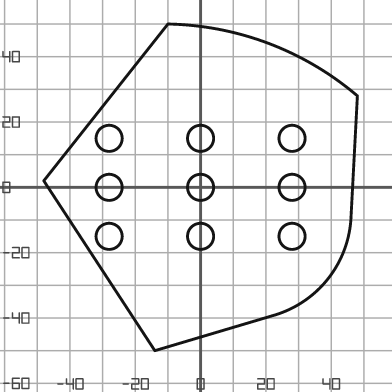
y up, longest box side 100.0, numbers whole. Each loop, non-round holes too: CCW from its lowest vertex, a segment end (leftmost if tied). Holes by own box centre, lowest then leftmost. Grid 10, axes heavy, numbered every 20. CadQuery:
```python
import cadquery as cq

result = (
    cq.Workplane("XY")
    .moveTo(-14.0, -50.0)
    .lineTo(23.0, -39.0)
    .threePointArc((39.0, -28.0), (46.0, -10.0))
    .lineTo(48.0, 28.0)
    .threePointArc((21.0, 44.0), (-10.0, 50.0))
    .lineTo(-48.0, 2.0)
    .close()
    .moveTo(-28.0, -15.0)
    .circle(4.0)
    .moveTo(0.0, -15.0)
    .circle(4.0)
    .moveTo(28.0, -15.0)
    .circle(4.0)
    .moveTo(-28.0, 0.0)
    .circle(4.0)
    .moveTo(0.0, 0.0)
    .circle(4.0)
    .moveTo(28.0, 0.0)
    .circle(4.0)
    .moveTo(-28.0, 15.0)
    .circle(4.0)
    .moveTo(0.0, 15.0)
    .circle(4.0)
    .moveTo(28.0, 15.0)
    .circle(4.0)
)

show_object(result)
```